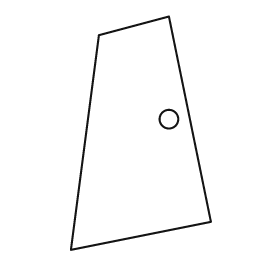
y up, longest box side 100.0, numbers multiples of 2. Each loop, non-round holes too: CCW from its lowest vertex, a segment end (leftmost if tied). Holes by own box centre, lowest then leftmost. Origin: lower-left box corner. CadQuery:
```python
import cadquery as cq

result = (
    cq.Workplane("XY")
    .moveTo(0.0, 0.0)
    .lineTo(60.0, 12.0)
    .lineTo(42.0, 100.0)
    .lineTo(12.0, 92.0)
    .close()
    .moveTo(42.0, 56.0)
    .circle(4.0)
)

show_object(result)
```